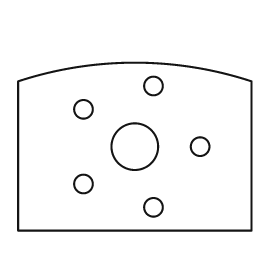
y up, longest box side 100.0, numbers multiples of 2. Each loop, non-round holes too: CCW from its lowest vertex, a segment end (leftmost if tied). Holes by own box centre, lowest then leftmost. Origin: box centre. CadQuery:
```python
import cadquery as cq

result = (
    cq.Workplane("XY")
    .moveTo(-50.0, -36.0)
    .lineTo(50.0, -36.0)
    .lineTo(50.0, 28.0)
    .threePointArc((0.0, 36.0), (-50.0, 28.0))
    .close()
    .moveTo(8.0, -26.0)
    .circle(4.0)
    .moveTo(-22.0, -16.0)
    .circle(4.0)
    .moveTo(0.0, 0.0)
    .circle(10.0)
    .moveTo(28.0, 0.0)
    .circle(4.0)
    .moveTo(-22.0, 16.0)
    .circle(4.0)
    .moveTo(8.0, 26.0)
    .circle(4.0)
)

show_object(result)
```